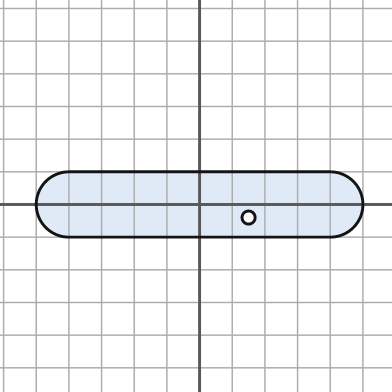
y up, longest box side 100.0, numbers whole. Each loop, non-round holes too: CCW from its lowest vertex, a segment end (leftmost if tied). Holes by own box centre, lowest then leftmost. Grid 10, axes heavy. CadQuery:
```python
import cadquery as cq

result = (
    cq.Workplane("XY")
    .moveTo(-40.0, -10.0)
    .lineTo(40.0, -10.0)
    .threePointArc((50.0, 0.0), (40.0, 10.0))
    .lineTo(-40.0, 10.0)
    .threePointArc((-50.0, 0.0), (-40.0, -10.0))
    .close()
    .moveTo(15.0, -4.0)
    .circle(2.0)
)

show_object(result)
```